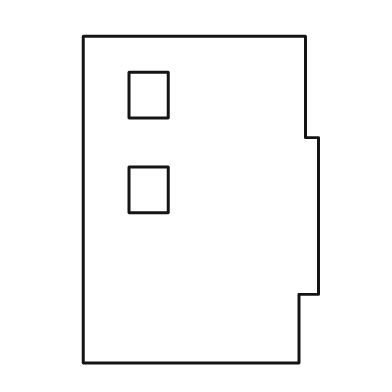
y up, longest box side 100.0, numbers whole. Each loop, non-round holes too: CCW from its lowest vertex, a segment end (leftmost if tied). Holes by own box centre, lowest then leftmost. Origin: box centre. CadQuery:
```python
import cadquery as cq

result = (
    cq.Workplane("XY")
    .moveTo(-36.0, -50.0)
    .lineTo(30.0, -50.0)
    .lineTo(30.0, -29.0)
    .lineTo(36.0, -29.0)
    .lineTo(36.0, 19.0)
    .lineTo(32.0, 19.0)
    .lineTo(32.0, 50.0)
    .lineTo(-36.0, 50.0)
    .close()
    .moveTo(-22.0, -4.0)
    .lineTo(-10.0, -4.0)
    .lineTo(-10.0, 10.0)
    .lineTo(-22.0, 10.0)
    .close()
    .moveTo(-22.0, 25.0)
    .lineTo(-10.0, 25.0)
    .lineTo(-10.0, 39.0)
    .lineTo(-22.0, 39.0)
    .close()
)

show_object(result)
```